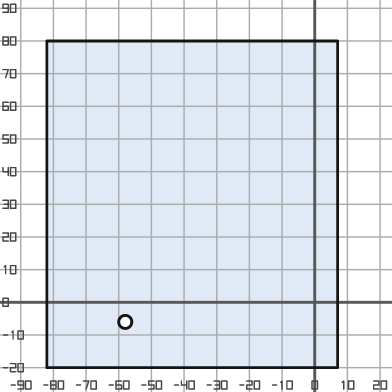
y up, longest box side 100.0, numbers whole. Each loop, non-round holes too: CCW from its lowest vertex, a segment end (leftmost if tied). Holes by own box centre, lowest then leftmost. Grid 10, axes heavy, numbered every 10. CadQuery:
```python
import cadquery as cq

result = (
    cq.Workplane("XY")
    .moveTo(-82.0, -20.0)
    .lineTo(7.0, -20.0)
    .lineTo(7.0, 80.0)
    .lineTo(-82.0, 80.0)
    .close()
    .moveTo(-58.0, -6.0)
    .circle(2.0)
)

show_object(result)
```